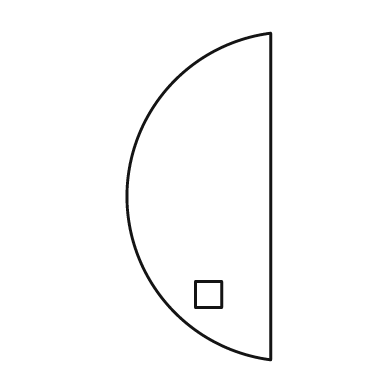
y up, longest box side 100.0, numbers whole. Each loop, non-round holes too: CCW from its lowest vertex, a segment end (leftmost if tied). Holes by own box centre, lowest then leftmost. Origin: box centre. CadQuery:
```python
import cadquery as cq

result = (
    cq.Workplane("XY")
    .moveTo(22.0, -50.0)
    .lineTo(22.0, 50.0)
    .threePointArc((-22.0, 0.0), (22.0, -50.0))
    .close()
    .moveTo(-1.0, -34.0)
    .lineTo(7.0, -34.0)
    .lineTo(7.0, -26.0)
    .lineTo(-1.0, -26.0)
    .close()
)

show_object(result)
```